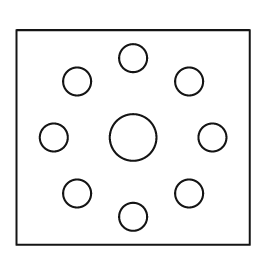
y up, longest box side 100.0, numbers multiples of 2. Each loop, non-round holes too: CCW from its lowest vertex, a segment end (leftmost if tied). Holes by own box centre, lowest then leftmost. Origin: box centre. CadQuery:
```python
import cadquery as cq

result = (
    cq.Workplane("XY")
    .moveTo(-50.0, -46.0)
    .lineTo(50.0, -46.0)
    .lineTo(50.0, 46.0)
    .lineTo(-50.0, 46.0)
    .close()
    .moveTo(0.0, -34.0)
    .circle(6.0)
    .moveTo(-24.0, -24.0)
    .circle(6.0)
    .moveTo(24.0, -24.0)
    .circle(6.0)
    .moveTo(-34.0, 0.0)
    .circle(6.0)
    .moveTo(0.0, 0.0)
    .circle(10.0)
    .moveTo(34.0, 0.0)
    .circle(6.0)
    .moveTo(-24.0, 24.0)
    .circle(6.0)
    .moveTo(24.0, 24.0)
    .circle(6.0)
    .moveTo(0.0, 34.0)
    .circle(6.0)
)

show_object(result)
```